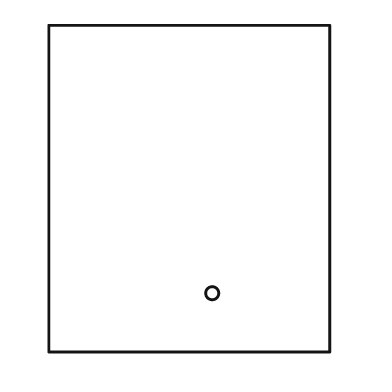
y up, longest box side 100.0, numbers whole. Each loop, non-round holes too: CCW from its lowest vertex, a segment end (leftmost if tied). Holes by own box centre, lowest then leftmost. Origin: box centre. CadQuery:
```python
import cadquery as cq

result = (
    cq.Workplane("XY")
    .moveTo(-43.0, -50.0)
    .lineTo(43.0, -50.0)
    .lineTo(43.0, 50.0)
    .lineTo(-43.0, 50.0)
    .close()
    .moveTo(7.0, -32.0)
    .circle(2.0)
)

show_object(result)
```